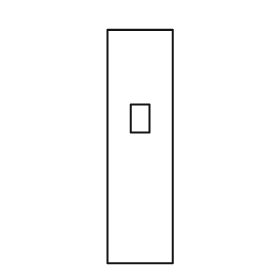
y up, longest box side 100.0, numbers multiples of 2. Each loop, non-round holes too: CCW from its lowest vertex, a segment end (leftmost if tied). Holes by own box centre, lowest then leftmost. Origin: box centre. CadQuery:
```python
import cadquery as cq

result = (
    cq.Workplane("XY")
    .moveTo(-14.0, -50.0)
    .lineTo(14.0, -50.0)
    .lineTo(14.0, 50.0)
    .lineTo(-14.0, 50.0)
    .close()
    .moveTo(-4.0, 6.0)
    .lineTo(4.0, 6.0)
    .lineTo(4.0, 18.0)
    .lineTo(-4.0, 18.0)
    .close()
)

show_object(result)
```